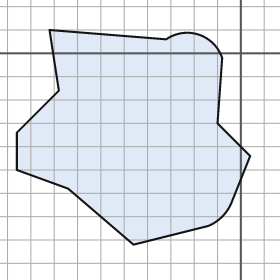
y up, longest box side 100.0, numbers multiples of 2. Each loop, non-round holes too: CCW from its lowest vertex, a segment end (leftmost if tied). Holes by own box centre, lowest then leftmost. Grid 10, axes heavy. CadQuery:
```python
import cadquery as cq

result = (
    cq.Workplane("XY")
    .moveTo(-46.0, -82.0)
    .lineTo(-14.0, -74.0)
    .threePointArc((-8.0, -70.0), (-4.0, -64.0))
    .lineTo(4.0, -44.0)
    .lineTo(-10.0, -30.0)
    .lineTo(-8.0, -2.0)
    .threePointArc((-18.0, 8.0), (-32.0, 6.0))
    .lineTo(-82.0, 10.0)
    .lineTo(-78.0, -16.0)
    .lineTo(-96.0, -34.0)
    .lineTo(-96.0, -50.0)
    .lineTo(-74.0, -58.0)
    .close()
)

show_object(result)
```